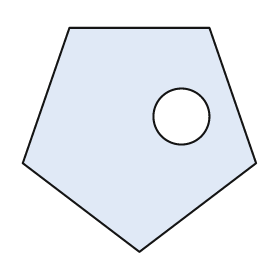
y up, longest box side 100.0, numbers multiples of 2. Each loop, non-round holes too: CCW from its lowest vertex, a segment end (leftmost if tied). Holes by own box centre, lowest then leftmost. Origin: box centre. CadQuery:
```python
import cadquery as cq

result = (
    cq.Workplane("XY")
    .moveTo(0.0, -48.0)
    .lineTo(50.0, -10.0)
    .lineTo(30.0, 48.0)
    .lineTo(-30.0, 48.0)
    .lineTo(-50.0, -10.0)
    .close()
    .moveTo(18.0, 10.0)
    .circle(12.0)
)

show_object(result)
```